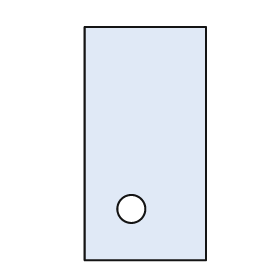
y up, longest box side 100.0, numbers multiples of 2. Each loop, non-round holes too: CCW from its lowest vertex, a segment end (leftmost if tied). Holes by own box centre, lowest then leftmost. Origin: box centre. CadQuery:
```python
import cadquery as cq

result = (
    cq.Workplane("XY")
    .moveTo(-26.0, -50.0)
    .lineTo(26.0, -50.0)
    .lineTo(26.0, 50.0)
    .lineTo(-26.0, 50.0)
    .close()
    .moveTo(-6.0, -28.0)
    .circle(6.0)
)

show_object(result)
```